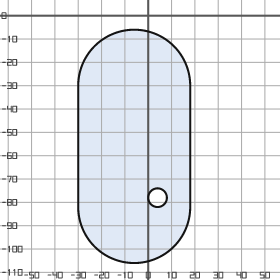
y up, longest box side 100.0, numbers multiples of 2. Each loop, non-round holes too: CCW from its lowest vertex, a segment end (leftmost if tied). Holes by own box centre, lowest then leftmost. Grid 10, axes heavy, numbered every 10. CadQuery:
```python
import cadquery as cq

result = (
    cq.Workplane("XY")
    .moveTo(-30.0, -82.0)
    .threePointArc((-6.0, -106.0), (18.0, -82.0))
    .lineTo(18.0, -30.0)
    .threePointArc((-6.0, -6.0), (-30.0, -30.0))
    .close()
    .moveTo(4.0, -78.0)
    .circle(4.0)
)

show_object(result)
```